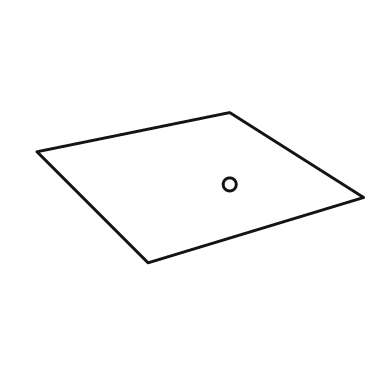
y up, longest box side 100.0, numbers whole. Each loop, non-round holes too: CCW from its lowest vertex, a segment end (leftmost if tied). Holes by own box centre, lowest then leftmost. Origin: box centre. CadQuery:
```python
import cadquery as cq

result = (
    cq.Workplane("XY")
    .moveTo(-16.0, -23.0)
    .lineTo(50.0, -3.0)
    .lineTo(9.0, 23.0)
    .lineTo(-50.0, 11.0)
    .close()
    .moveTo(9.0, 1.0)
    .circle(2.0)
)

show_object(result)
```